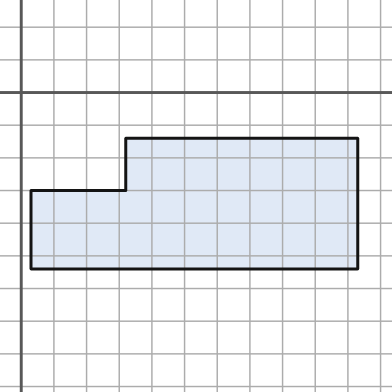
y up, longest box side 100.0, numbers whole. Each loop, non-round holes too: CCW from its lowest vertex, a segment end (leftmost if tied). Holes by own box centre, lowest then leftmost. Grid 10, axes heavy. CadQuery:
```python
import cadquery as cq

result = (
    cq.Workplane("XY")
    .moveTo(3.0, -54.0)
    .lineTo(103.0, -54.0)
    .lineTo(103.0, -14.0)
    .lineTo(32.0, -14.0)
    .lineTo(32.0, -30.0)
    .lineTo(3.0, -30.0)
    .close()
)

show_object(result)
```